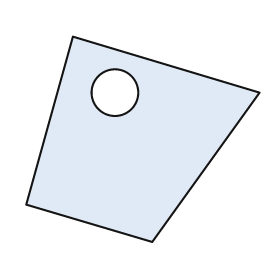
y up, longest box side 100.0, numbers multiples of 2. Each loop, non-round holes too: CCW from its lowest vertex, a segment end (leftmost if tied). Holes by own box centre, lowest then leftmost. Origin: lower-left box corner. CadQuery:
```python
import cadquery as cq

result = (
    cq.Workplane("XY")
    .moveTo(54.0, 0.0)
    .lineTo(100.0, 64.0)
    .lineTo(20.0, 88.0)
    .lineTo(0.0, 16.0)
    .close()
    .moveTo(38.0, 64.0)
    .circle(10.0)
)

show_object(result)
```